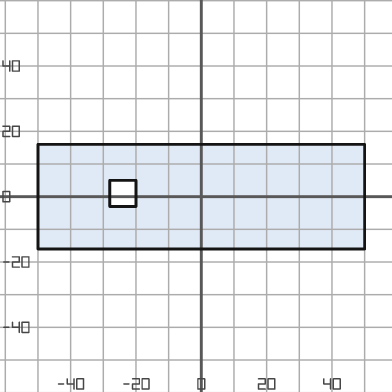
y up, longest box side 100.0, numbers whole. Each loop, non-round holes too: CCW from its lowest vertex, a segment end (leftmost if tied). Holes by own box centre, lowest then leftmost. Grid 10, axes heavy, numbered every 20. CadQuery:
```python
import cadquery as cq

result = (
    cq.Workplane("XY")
    .moveTo(-50.0, -16.0)
    .lineTo(50.0, -16.0)
    .lineTo(50.0, 16.0)
    .lineTo(-50.0, 16.0)
    .close()
    .moveTo(-28.0, -3.0)
    .lineTo(-20.0, -3.0)
    .lineTo(-20.0, 5.0)
    .lineTo(-28.0, 5.0)
    .close()
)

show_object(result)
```